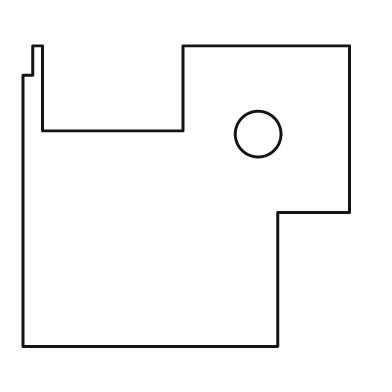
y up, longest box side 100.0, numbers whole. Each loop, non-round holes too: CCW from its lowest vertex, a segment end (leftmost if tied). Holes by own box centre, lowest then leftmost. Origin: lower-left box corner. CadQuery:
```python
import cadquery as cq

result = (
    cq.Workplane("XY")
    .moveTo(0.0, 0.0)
    .lineTo(78.0, 0.0)
    .lineTo(78.0, 41.0)
    .lineTo(100.0, 41.0)
    .lineTo(100.0, 92.0)
    .lineTo(49.0, 92.0)
    .lineTo(49.0, 66.0)
    .lineTo(6.0, 66.0)
    .lineTo(6.0, 92.0)
    .lineTo(3.0, 92.0)
    .lineTo(3.0, 83.0)
    .lineTo(0.0, 83.0)
    .close()
    .moveTo(72.0, 65.0)
    .circle(7.0)
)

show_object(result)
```